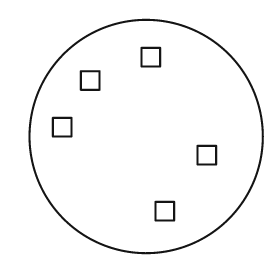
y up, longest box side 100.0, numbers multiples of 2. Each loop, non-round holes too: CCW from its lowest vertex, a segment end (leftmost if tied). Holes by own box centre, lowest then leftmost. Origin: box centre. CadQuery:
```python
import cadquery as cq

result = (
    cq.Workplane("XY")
    .moveTo(0.0, 0.0)
    .circle(50.0)
    .moveTo(4.0, -36.0)
    .lineTo(12.0, -36.0)
    .lineTo(12.0, -28.0)
    .lineTo(4.0, -28.0)
    .close()
    .moveTo(22.0, -12.0)
    .lineTo(30.0, -12.0)
    .lineTo(30.0, -4.0)
    .lineTo(22.0, -4.0)
    .close()
    .moveTo(-40.0, 0.0)
    .lineTo(-32.0, 0.0)
    .lineTo(-32.0, 8.0)
    .lineTo(-40.0, 8.0)
    .close()
    .moveTo(-28.0, 20.0)
    .lineTo(-20.0, 20.0)
    .lineTo(-20.0, 28.0)
    .lineTo(-28.0, 28.0)
    .close()
    .moveTo(-2.0, 30.0)
    .lineTo(6.0, 30.0)
    .lineTo(6.0, 38.0)
    .lineTo(-2.0, 38.0)
    .close()
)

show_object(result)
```